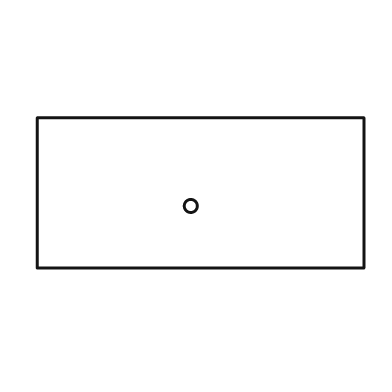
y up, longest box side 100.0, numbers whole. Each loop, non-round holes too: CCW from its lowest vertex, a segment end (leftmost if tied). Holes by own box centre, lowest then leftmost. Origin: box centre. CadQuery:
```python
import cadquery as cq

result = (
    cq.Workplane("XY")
    .moveTo(-50.0, -23.0)
    .lineTo(50.0, -23.0)
    .lineTo(50.0, 23.0)
    .lineTo(-50.0, 23.0)
    .close()
    .moveTo(-3.0, -4.0)
    .circle(2.0)
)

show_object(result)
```